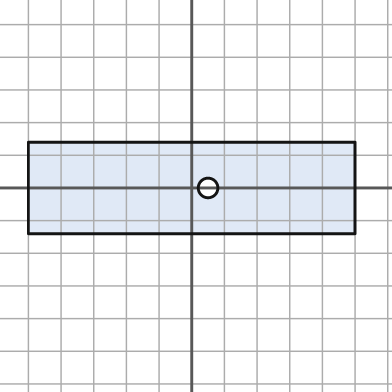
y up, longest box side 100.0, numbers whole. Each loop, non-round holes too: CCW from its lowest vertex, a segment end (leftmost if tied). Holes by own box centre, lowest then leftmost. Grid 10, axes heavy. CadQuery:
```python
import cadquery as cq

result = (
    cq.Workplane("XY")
    .moveTo(-50.0, -14.0)
    .lineTo(50.0, -14.0)
    .lineTo(50.0, 14.0)
    .lineTo(-50.0, 14.0)
    .close()
    .moveTo(5.0, 0.0)
    .circle(3.0)
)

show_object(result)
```